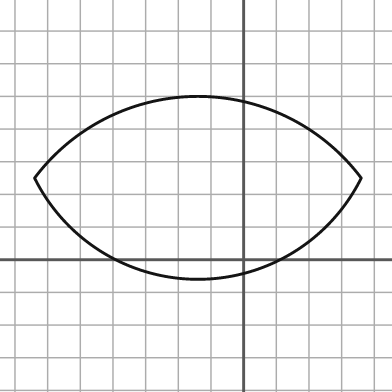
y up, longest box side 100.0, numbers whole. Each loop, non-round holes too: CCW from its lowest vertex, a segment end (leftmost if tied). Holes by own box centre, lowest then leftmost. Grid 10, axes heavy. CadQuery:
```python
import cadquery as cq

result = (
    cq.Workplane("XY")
    .moveTo(-64.0, 25.0)
    .threePointArc((-14.0, -6.0), (36.0, 25.0))
    .threePointArc((-14.0, 50.0), (-64.0, 25.0))
    .close()
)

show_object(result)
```